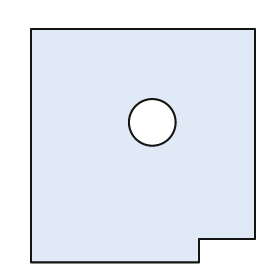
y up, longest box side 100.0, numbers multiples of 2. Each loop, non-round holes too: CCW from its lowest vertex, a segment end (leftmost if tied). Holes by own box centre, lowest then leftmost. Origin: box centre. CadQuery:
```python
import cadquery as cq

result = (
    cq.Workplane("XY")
    .moveTo(-48.0, -50.0)
    .lineTo(24.0, -50.0)
    .lineTo(24.0, -40.0)
    .lineTo(48.0, -40.0)
    .lineTo(48.0, 50.0)
    .lineTo(-48.0, 50.0)
    .close()
    .moveTo(4.0, 10.0)
    .circle(10.0)
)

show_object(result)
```